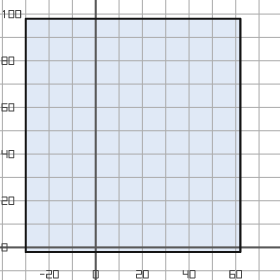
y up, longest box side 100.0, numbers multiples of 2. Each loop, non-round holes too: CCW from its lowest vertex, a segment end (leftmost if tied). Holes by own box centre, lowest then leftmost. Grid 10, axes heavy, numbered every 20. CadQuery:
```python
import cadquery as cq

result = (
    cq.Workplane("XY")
    .moveTo(-30.0, -2.0)
    .lineTo(62.0, -2.0)
    .lineTo(62.0, 98.0)
    .lineTo(-30.0, 98.0)
    .close()
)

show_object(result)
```